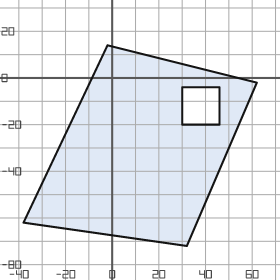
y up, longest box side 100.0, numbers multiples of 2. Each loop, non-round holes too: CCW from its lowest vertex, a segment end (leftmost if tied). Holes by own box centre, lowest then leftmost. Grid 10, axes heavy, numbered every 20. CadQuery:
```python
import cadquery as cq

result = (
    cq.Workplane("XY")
    .moveTo(32.0, -72.0)
    .lineTo(62.0, -2.0)
    .lineTo(-2.0, 14.0)
    .lineTo(-38.0, -62.0)
    .close()
    .moveTo(30.0, -20.0)
    .lineTo(46.0, -20.0)
    .lineTo(46.0, -4.0)
    .lineTo(30.0, -4.0)
    .close()
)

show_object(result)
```